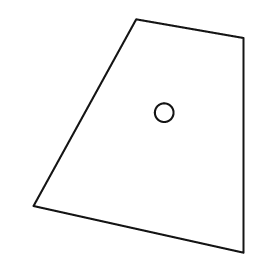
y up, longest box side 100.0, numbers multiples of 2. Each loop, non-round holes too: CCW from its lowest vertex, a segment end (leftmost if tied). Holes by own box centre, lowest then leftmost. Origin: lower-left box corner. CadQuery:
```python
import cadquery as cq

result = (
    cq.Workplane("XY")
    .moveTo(90.0, 0.0)
    .lineTo(90.0, 92.0)
    .lineTo(44.0, 100.0)
    .lineTo(0.0, 20.0)
    .close()
    .moveTo(56.0, 60.0)
    .circle(4.0)
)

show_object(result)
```